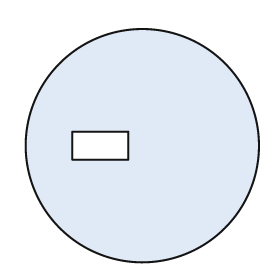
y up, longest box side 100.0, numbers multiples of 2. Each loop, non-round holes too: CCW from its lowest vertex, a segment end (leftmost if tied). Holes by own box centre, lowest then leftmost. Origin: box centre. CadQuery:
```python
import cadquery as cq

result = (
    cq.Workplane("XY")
    .moveTo(0.0, 0.0)
    .circle(50.0)
    .moveTo(-30.0, -6.0)
    .lineTo(-6.0, -6.0)
    .lineTo(-6.0, 6.0)
    .lineTo(-30.0, 6.0)
    .close()
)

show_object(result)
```